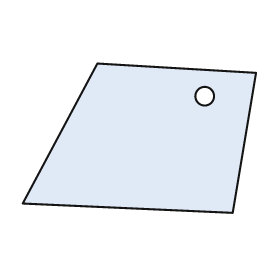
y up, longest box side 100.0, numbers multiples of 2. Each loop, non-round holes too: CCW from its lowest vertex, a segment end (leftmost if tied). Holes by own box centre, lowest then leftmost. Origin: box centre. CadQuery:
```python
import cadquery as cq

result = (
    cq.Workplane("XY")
    .moveTo(40.0, -32.0)
    .lineTo(50.0, 28.0)
    .lineTo(-18.0, 32.0)
    .lineTo(-50.0, -28.0)
    .close()
    .moveTo(28.0, 18.0)
    .circle(4.0)
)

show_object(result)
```